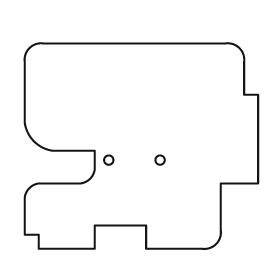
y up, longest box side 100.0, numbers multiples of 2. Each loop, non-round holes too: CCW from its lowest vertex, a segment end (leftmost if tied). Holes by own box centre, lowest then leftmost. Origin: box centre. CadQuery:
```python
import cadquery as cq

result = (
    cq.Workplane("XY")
    .moveTo(-44.0, -44.0)
    .lineTo(-20.0, -44.0)
    .lineTo(-20.0, -34.0)
    .lineTo(2.0, -34.0)
    .lineTo(2.0, -44.0)
    .lineTo(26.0, -44.0)
    .threePointArc((32.0, -42.0), (34.0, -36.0))
    .lineTo(34.0, -16.0)
    .lineTo(50.0, -16.0)
    .lineTo(50.0, 22.0)
    .lineTo(44.0, 22.0)
    .lineTo(44.0, 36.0)
    .threePointArc((42.0, 42.0), (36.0, 44.0))
    .lineTo(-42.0, 44.0)
    .threePointArc((-48.0, 42.0), (-50.0, 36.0))
    .lineTo(-50.0, 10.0)
    .threePointArc((-46.0, 2.0), (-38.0, -2.0))
    .lineTo(-20.0, -2.0)
    .lineTo(-20.0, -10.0)
    .threePointArc((-22.0, -14.0), (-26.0, -16.0))
    .lineTo(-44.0, -16.0)
    .threePointArc((-48.0, -18.0), (-50.0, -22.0))
    .lineTo(-50.0, -38.0)
    .lineTo(-44.0, -38.0)
    .close()
    .moveTo(-14.0, -6.0)
    .circle(2.0)
    .moveTo(8.0, -6.0)
    .circle(2.0)
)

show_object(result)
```